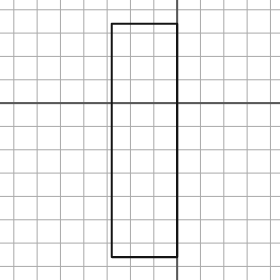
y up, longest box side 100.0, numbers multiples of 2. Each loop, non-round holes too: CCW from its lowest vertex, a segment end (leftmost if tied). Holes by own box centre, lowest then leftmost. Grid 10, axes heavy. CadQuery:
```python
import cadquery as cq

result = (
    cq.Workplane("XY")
    .moveTo(-28.0, -66.0)
    .lineTo(0.0, -66.0)
    .lineTo(0.0, 34.0)
    .lineTo(-28.0, 34.0)
    .close()
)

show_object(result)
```